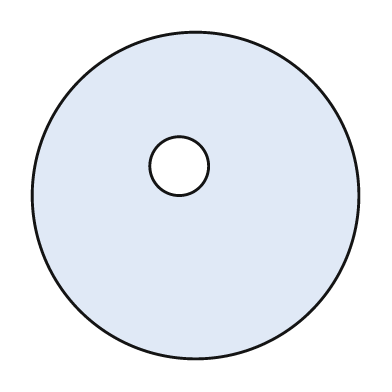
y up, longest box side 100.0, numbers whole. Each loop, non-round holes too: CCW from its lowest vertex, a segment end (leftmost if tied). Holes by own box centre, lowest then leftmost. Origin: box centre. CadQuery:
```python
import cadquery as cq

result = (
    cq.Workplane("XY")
    .moveTo(0.0, 0.0)
    .circle(50.0)
    .moveTo(-5.0, 9.0)
    .circle(9.0)
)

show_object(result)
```